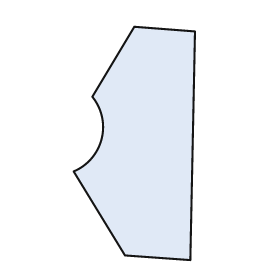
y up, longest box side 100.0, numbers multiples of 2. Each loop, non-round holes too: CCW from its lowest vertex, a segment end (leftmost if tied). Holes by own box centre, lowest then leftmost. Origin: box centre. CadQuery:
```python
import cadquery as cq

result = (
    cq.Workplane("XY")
    .moveTo(24.0, -50.0)
    .lineTo(26.0, 48.0)
    .lineTo(0.0, 50.0)
    .lineTo(-18.0, 20.0)
    .threePointArc((-14.0, 2.0), (-26.0, -12.0))
    .lineTo(-4.0, -48.0)
    .close()
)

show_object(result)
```